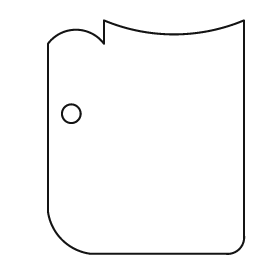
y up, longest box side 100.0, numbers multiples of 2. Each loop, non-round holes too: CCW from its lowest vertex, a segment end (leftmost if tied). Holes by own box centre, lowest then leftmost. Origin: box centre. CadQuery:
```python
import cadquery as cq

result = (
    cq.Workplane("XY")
    .moveTo(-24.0, -50.0)
    .lineTo(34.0, -50.0)
    .threePointArc((40.0, -48.0), (42.0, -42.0))
    .lineTo(42.0, 50.0)
    .threePointArc((12.0, 44.0), (-18.0, 50.0))
    .lineTo(-18.0, 40.0)
    .threePointArc((-30.0, 46.0), (-42.0, 40.0))
    .lineTo(-42.0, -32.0)
    .threePointArc((-36.0, -44.0), (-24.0, -50.0))
    .close()
    .moveTo(-32.0, 10.0)
    .circle(4.0)
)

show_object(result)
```